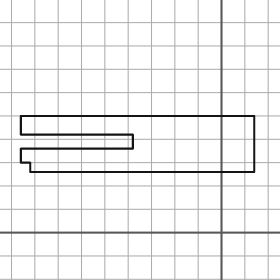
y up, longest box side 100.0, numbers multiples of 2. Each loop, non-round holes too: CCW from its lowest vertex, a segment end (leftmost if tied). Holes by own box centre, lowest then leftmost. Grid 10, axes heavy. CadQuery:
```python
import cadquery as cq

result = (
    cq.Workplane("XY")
    .moveTo(-82.0, 26.0)
    .lineTo(14.0, 26.0)
    .lineTo(14.0, 50.0)
    .lineTo(-86.0, 50.0)
    .lineTo(-86.0, 42.0)
    .lineTo(-38.0, 42.0)
    .lineTo(-38.0, 36.0)
    .lineTo(-86.0, 36.0)
    .lineTo(-86.0, 30.0)
    .lineTo(-82.0, 30.0)
    .close()
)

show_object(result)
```